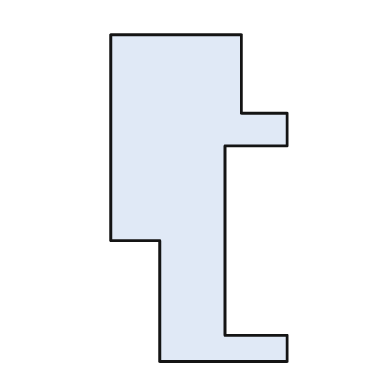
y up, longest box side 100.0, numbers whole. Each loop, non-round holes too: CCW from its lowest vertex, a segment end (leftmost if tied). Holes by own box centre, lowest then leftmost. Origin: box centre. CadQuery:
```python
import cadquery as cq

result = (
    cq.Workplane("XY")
    .moveTo(-12.0, -50.0)
    .lineTo(27.0, -50.0)
    .lineTo(27.0, -42.0)
    .lineTo(8.0, -42.0)
    .lineTo(8.0, 16.0)
    .lineTo(27.0, 16.0)
    .lineTo(27.0, 26.0)
    .lineTo(13.0, 26.0)
    .lineTo(13.0, 50.0)
    .lineTo(-27.0, 50.0)
    .lineTo(-27.0, -13.0)
    .lineTo(-12.0, -13.0)
    .close()
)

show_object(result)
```